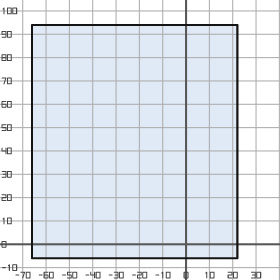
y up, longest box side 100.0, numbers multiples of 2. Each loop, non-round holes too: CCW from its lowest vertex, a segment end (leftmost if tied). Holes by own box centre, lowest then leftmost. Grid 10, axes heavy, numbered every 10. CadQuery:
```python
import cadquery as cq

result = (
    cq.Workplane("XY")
    .moveTo(-66.0, -6.0)
    .lineTo(22.0, -6.0)
    .lineTo(22.0, 94.0)
    .lineTo(-66.0, 94.0)
    .close()
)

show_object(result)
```